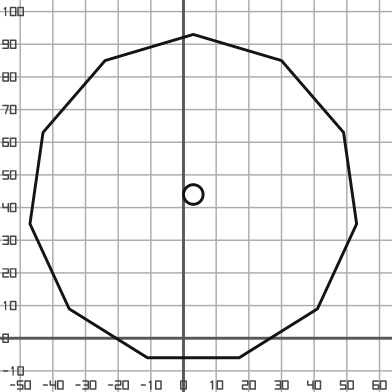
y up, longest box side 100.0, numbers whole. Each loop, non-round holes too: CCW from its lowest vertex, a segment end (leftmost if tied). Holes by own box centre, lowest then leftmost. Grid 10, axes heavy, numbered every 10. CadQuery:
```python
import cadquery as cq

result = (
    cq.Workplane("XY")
    .moveTo(-11.0, -6.0)
    .lineTo(17.0, -6.0)
    .lineTo(41.0, 9.0)
    .lineTo(53.0, 35.0)
    .lineTo(49.0, 63.0)
    .lineTo(30.0, 85.0)
    .lineTo(3.0, 93.0)
    .lineTo(-24.0, 85.0)
    .lineTo(-43.0, 63.0)
    .lineTo(-47.0, 35.0)
    .lineTo(-35.0, 9.0)
    .close()
    .moveTo(3.0, 44.0)
    .circle(3.0)
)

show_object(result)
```